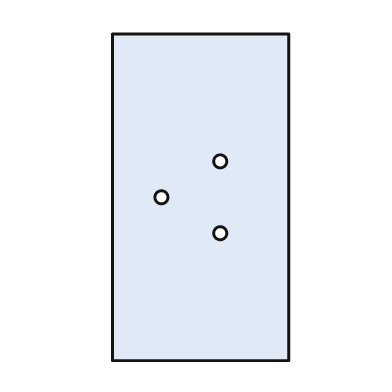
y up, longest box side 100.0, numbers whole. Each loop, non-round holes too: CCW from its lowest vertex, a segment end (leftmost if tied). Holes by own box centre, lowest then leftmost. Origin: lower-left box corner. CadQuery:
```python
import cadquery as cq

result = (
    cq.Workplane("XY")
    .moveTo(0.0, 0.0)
    .lineTo(54.0, 0.0)
    .lineTo(54.0, 100.0)
    .lineTo(0.0, 100.0)
    .close()
    .moveTo(33.0, 39.0)
    .circle(2.0)
    .moveTo(15.0, 50.0)
    .circle(2.0)
    .moveTo(33.0, 61.0)
    .circle(2.0)
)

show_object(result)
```